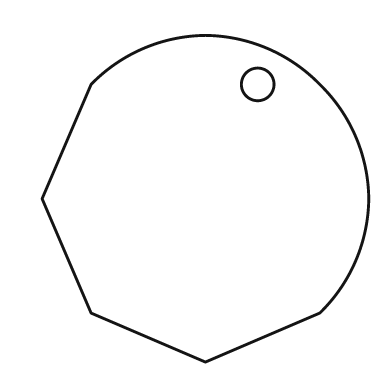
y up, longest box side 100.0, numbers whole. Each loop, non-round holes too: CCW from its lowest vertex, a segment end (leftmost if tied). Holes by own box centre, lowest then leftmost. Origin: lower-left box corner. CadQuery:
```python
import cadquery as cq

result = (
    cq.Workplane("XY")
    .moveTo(50.0, 0.0)
    .lineTo(85.0, 15.0)
    .threePointArc((96.0, 31.0), (100.0, 50.0))
    .threePointArc((96.0, 69.0), (85.0, 85.0))
    .threePointArc((69.0, 96.0), (50.0, 100.0))
    .threePointArc((31.0, 96.0), (15.0, 85.0))
    .lineTo(0.0, 50.0)
    .lineTo(15.0, 15.0)
    .close()
    .moveTo(66.0, 85.0)
    .circle(5.0)
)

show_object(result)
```